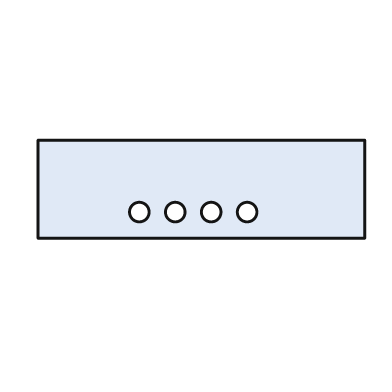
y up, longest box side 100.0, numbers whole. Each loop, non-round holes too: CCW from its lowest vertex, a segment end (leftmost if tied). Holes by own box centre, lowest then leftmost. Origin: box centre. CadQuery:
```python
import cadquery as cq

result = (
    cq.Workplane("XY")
    .moveTo(-50.0, -15.0)
    .lineTo(50.0, -15.0)
    .lineTo(50.0, 15.0)
    .lineTo(-50.0, 15.0)
    .close()
    .moveTo(-19.0, -7.0)
    .circle(3.0)
    .moveTo(-8.0, -7.0)
    .circle(3.0)
    .moveTo(3.0, -7.0)
    .circle(3.0)
    .moveTo(14.0, -7.0)
    .circle(3.0)
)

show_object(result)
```